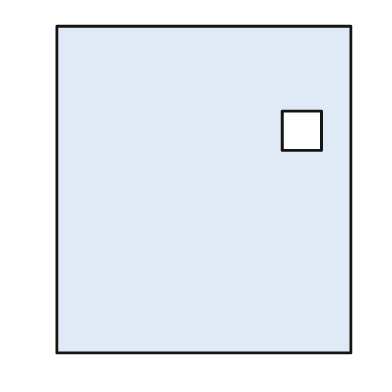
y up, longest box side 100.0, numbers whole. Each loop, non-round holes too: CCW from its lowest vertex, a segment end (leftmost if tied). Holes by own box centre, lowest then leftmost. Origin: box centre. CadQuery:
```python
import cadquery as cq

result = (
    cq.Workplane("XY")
    .moveTo(-45.0, -50.0)
    .lineTo(45.0, -50.0)
    .lineTo(45.0, 50.0)
    .lineTo(-45.0, 50.0)
    .close()
    .moveTo(24.0, 12.0)
    .lineTo(36.0, 12.0)
    .lineTo(36.0, 24.0)
    .lineTo(24.0, 24.0)
    .close()
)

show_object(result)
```